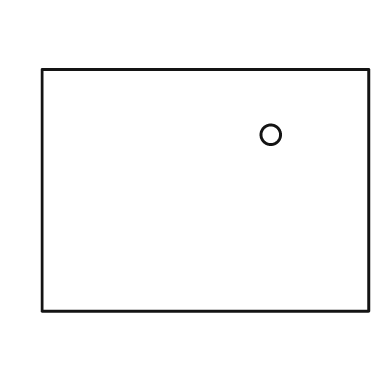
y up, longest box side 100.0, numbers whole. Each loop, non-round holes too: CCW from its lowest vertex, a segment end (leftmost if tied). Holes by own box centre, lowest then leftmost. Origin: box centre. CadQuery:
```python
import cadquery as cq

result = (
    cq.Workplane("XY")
    .moveTo(-50.0, -37.0)
    .lineTo(50.0, -37.0)
    .lineTo(50.0, 37.0)
    .lineTo(-50.0, 37.0)
    .close()
    .moveTo(20.0, 17.0)
    .circle(3.0)
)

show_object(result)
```